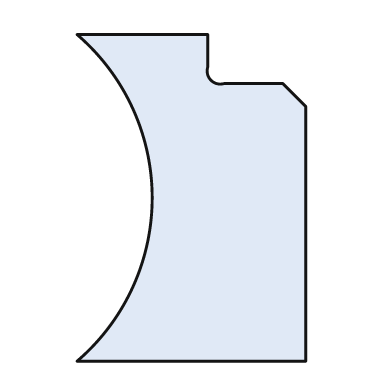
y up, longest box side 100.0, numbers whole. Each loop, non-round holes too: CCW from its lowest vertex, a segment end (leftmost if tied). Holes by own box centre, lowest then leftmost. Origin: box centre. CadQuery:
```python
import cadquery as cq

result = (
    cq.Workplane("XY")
    .moveTo(-35.0, -50.0)
    .lineTo(35.0, -50.0)
    .lineTo(35.0, 28.0)
    .lineTo(28.0, 35.0)
    .lineTo(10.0, 35.0)
    .threePointArc((6.0, 36.0), (5.0, 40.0))
    .lineTo(5.0, 50.0)
    .lineTo(-35.0, 50.0)
    .threePointArc((-12.0, 0.0), (-35.0, -50.0))
    .close()
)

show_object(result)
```